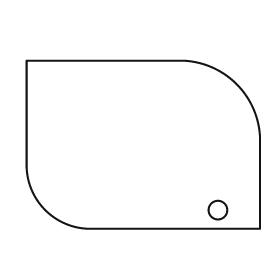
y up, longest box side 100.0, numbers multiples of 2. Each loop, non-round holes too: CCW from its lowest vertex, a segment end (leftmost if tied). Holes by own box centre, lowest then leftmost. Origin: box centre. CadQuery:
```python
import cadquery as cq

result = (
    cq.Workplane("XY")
    .moveTo(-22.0, -36.0)
    .lineTo(50.0, -36.0)
    .lineTo(50.0, 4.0)
    .threePointArc((40.0, 26.0), (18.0, 36.0))
    .lineTo(-50.0, 36.0)
    .lineTo(-50.0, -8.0)
    .threePointArc((-42.0, -28.0), (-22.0, -36.0))
    .close()
    .moveTo(32.0, -28.0)
    .circle(4.0)
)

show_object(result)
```